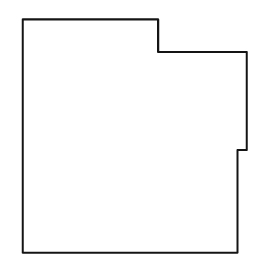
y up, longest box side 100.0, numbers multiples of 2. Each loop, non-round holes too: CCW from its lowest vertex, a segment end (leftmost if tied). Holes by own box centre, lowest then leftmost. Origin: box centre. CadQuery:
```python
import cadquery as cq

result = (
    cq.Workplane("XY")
    .moveTo(-48.0, -50.0)
    .lineTo(44.0, -50.0)
    .lineTo(44.0, -6.0)
    .lineTo(48.0, -6.0)
    .lineTo(48.0, 36.0)
    .lineTo(10.0, 36.0)
    .lineTo(10.0, 50.0)
    .lineTo(-48.0, 50.0)
    .close()
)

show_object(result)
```